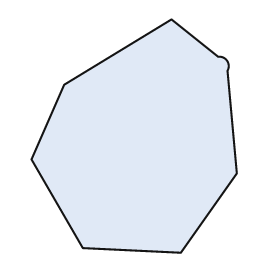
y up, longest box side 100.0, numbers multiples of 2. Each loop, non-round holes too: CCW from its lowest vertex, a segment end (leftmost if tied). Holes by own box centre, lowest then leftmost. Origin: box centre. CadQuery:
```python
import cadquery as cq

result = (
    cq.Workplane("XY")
    .moveTo(20.0, -50.0)
    .lineTo(44.0, -16.0)
    .lineTo(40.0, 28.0)
    .threePointArc((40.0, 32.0), (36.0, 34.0))
    .lineTo(16.0, 50.0)
    .lineTo(-30.0, 22.0)
    .lineTo(-44.0, -10.0)
    .lineTo(-22.0, -48.0)
    .close()
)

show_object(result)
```